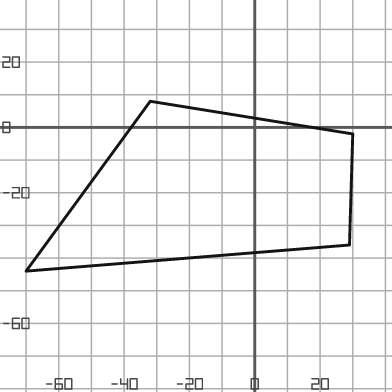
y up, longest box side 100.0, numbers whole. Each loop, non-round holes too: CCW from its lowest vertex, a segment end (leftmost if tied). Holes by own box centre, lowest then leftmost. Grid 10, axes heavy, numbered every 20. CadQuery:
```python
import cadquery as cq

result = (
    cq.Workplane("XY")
    .moveTo(-70.0, -44.0)
    .lineTo(29.0, -36.0)
    .lineTo(30.0, -2.0)
    .lineTo(-32.0, 8.0)
    .close()
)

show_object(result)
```